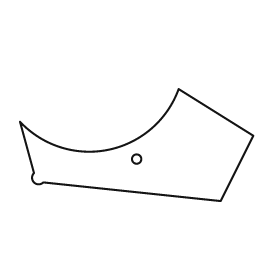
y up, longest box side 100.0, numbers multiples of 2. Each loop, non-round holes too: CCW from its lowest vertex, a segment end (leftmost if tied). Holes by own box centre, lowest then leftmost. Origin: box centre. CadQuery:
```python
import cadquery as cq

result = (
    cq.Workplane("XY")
    .moveTo(36.0, -24.0)
    .lineTo(50.0, 4.0)
    .lineTo(18.0, 24.0)
    .threePointArc((-12.0, -2.0), (-50.0, 10.0))
    .lineTo(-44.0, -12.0)
    .threePointArc((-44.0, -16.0), (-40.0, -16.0))
    .close()
    .moveTo(0.0, -6.0)
    .circle(2.0)
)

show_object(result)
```